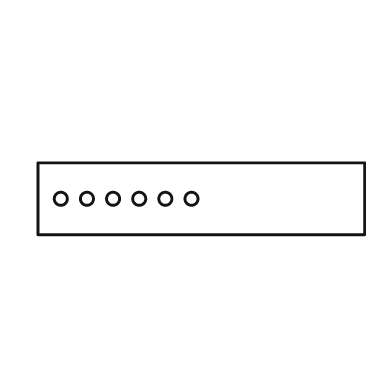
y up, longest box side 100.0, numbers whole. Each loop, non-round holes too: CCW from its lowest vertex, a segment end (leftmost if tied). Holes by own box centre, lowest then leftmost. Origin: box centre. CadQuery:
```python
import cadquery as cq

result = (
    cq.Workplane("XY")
    .moveTo(-50.0, -11.0)
    .lineTo(50.0, -11.0)
    .lineTo(50.0, 11.0)
    .lineTo(-50.0, 11.0)
    .close()
    .moveTo(-43.0, 0.0)
    .circle(2.0)
    .moveTo(-35.0, 0.0)
    .circle(2.0)
    .moveTo(-27.0, 0.0)
    .circle(2.0)
    .moveTo(-19.0, 0.0)
    .circle(2.0)
    .moveTo(-11.0, 0.0)
    .circle(2.0)
    .moveTo(-3.0, 0.0)
    .circle(2.0)
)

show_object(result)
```